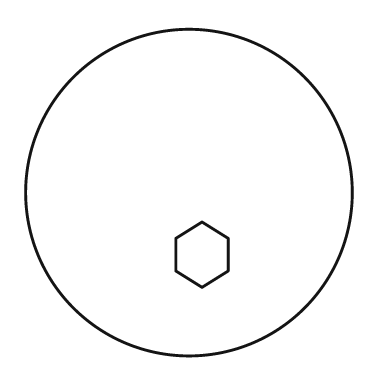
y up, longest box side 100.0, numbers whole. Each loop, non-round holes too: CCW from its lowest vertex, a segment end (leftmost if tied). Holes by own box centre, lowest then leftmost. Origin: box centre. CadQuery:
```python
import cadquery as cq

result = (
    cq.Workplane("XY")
    .moveTo(0.0, 0.0)
    .circle(50.0)
    .moveTo(4.0, -29.0)
    .lineTo(12.0, -24.0)
    .lineTo(12.0, -14.0)
    .lineTo(4.0, -9.0)
    .lineTo(-4.0, -14.0)
    .lineTo(-4.0, -24.0)
    .close()
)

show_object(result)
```